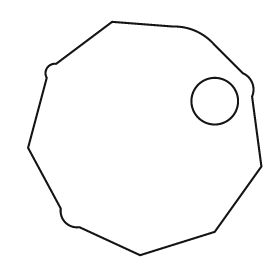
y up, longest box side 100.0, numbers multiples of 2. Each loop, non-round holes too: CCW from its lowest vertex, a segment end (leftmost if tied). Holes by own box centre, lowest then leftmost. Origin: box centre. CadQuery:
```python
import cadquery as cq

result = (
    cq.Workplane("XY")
    .moveTo(-2.0, -50.0)
    .lineTo(30.0, -40.0)
    .lineTo(50.0, -12.0)
    .lineTo(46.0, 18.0)
    .threePointArc((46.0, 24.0), (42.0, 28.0))
    .lineTo(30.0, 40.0)
    .threePointArc((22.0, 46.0), (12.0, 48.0))
    .lineTo(-14.0, 50.0)
    .lineTo(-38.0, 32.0)
    .threePointArc((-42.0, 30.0), (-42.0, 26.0))
    .lineTo(-50.0, -4.0)
    .lineTo(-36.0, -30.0)
    .threePointArc((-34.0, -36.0), (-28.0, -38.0))
    .close()
    .moveTo(30.0, 16.0)
    .circle(10.0)
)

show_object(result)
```